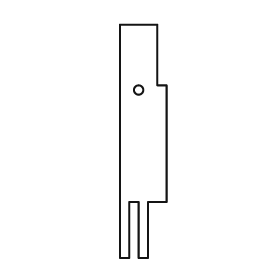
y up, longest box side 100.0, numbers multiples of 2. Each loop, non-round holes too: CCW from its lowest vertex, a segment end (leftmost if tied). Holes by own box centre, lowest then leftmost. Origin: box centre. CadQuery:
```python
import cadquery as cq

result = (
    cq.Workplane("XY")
    .moveTo(-10.0, -50.0)
    .lineTo(-6.0, -50.0)
    .lineTo(-6.0, -26.0)
    .lineTo(-2.0, -26.0)
    .lineTo(-2.0, -50.0)
    .lineTo(2.0, -50.0)
    .lineTo(2.0, -26.0)
    .lineTo(10.0, -26.0)
    .lineTo(10.0, 24.0)
    .lineTo(6.0, 24.0)
    .lineTo(6.0, 50.0)
    .lineTo(-10.0, 50.0)
    .close()
    .moveTo(-2.0, 22.0)
    .circle(2.0)
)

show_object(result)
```